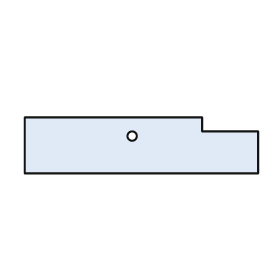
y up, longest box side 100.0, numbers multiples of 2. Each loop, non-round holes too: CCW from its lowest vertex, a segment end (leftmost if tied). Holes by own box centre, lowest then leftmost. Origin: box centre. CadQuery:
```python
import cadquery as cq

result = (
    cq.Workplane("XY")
    .moveTo(-50.0, -12.0)
    .lineTo(50.0, -12.0)
    .lineTo(50.0, 6.0)
    .lineTo(26.0, 6.0)
    .lineTo(26.0, 12.0)
    .lineTo(-50.0, 12.0)
    .close()
    .moveTo(-4.0, 4.0)
    .circle(2.0)
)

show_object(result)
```